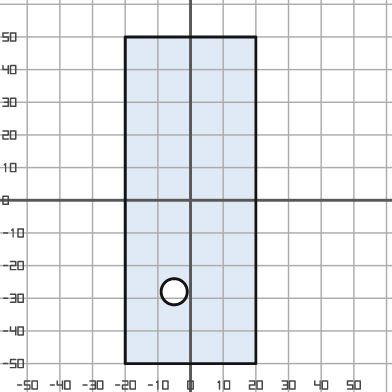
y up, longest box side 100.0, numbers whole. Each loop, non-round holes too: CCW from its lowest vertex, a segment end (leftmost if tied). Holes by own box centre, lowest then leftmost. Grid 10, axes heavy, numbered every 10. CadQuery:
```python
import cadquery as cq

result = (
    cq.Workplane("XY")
    .moveTo(-20.0, -50.0)
    .lineTo(20.0, -50.0)
    .lineTo(20.0, 50.0)
    .lineTo(-20.0, 50.0)
    .close()
    .moveTo(-5.0, -28.0)
    .circle(4.0)
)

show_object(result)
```